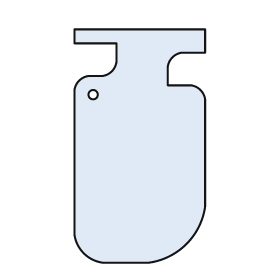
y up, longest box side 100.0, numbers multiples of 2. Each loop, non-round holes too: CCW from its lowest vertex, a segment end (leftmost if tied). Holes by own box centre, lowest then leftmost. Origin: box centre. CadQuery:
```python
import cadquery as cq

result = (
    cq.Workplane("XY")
    .moveTo(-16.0, -50.0)
    .lineTo(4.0, -50.0)
    .threePointArc((20.0, -42.0), (28.0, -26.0))
    .lineTo(28.0, 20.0)
    .threePointArc((26.0, 24.0), (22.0, 26.0))
    .lineTo(12.0, 26.0)
    .lineTo(12.0, 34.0)
    .threePointArc((14.0, 38.0), (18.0, 40.0))
    .lineTo(28.0, 40.0)
    .lineTo(28.0, 50.0)
    .lineTo(-28.0, 50.0)
    .lineTo(-28.0, 44.0)
    .lineTo(-10.0, 44.0)
    .lineTo(-10.0, 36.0)
    .threePointArc((-12.0, 32.0), (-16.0, 30.0))
    .lineTo(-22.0, 30.0)
    .threePointArc((-26.0, 28.0), (-28.0, 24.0))
    .lineTo(-28.0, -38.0)
    .threePointArc((-24.0, -46.0), (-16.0, -50.0))
    .close()
    .moveTo(-20.0, 22.0)
    .circle(2.0)
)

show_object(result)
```